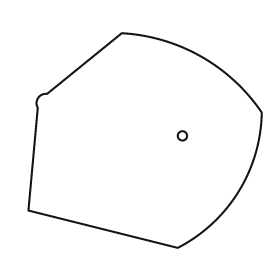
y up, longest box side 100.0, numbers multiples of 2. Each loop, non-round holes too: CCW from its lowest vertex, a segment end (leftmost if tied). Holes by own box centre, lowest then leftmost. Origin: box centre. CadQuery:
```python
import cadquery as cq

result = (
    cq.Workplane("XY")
    .moveTo(14.0, -46.0)
    .threePointArc((40.0, -22.0), (50.0, 12.0))
    .threePointArc((24.0, 36.0), (-10.0, 46.0))
    .lineTo(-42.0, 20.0)
    .threePointArc((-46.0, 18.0), (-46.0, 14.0))
    .lineTo(-50.0, -30.0)
    .close()
    .moveTo(16.0, 2.0)
    .circle(2.0)
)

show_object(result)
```